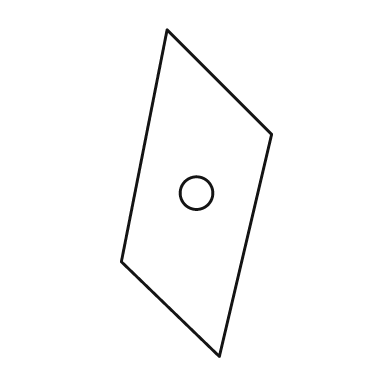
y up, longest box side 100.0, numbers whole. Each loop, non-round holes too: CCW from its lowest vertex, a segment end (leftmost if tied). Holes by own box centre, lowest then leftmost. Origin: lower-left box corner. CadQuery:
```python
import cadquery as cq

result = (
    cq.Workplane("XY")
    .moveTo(30.0, 0.0)
    .lineTo(46.0, 68.0)
    .lineTo(14.0, 100.0)
    .lineTo(0.0, 29.0)
    .close()
    .moveTo(23.0, 50.0)
    .circle(5.0)
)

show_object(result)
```